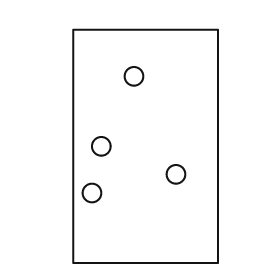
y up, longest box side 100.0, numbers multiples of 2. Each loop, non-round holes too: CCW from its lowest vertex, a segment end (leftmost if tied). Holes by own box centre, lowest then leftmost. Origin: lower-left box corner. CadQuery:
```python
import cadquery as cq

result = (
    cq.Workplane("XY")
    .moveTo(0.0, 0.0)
    .lineTo(62.0, 0.0)
    .lineTo(62.0, 100.0)
    .lineTo(0.0, 100.0)
    .close()
    .moveTo(8.0, 30.0)
    .circle(4.0)
    .moveTo(44.0, 38.0)
    .circle(4.0)
    .moveTo(12.0, 50.0)
    .circle(4.0)
    .moveTo(26.0, 80.0)
    .circle(4.0)
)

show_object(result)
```